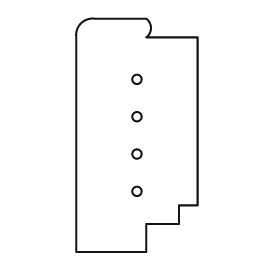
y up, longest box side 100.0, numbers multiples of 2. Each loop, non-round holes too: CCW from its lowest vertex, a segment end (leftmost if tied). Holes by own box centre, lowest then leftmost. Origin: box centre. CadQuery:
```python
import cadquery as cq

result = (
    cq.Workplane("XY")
    .moveTo(-26.0, -50.0)
    .lineTo(4.0, -50.0)
    .lineTo(4.0, -38.0)
    .lineTo(18.0, -38.0)
    .lineTo(18.0, -30.0)
    .lineTo(26.0, -30.0)
    .lineTo(26.0, 42.0)
    .lineTo(4.0, 42.0)
    .threePointArc((6.0, 46.0), (4.0, 50.0))
    .lineTo(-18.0, 50.0)
    .threePointArc((-24.0, 48.0), (-26.0, 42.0))
    .close()
    .moveTo(0.0, -24.0)
    .circle(2.0)
    .moveTo(0.0, -8.0)
    .circle(2.0)
    .moveTo(0.0, 8.0)
    .circle(2.0)
    .moveTo(0.0, 24.0)
    .circle(2.0)
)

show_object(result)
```